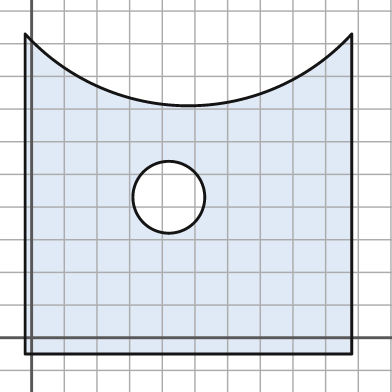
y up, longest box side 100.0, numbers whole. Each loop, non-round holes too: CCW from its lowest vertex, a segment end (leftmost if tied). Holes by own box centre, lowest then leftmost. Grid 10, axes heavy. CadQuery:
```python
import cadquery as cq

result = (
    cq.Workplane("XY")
    .moveTo(-2.0, -5.0)
    .lineTo(98.0, -5.0)
    .lineTo(98.0, 93.0)
    .threePointArc((48.0, 71.0), (-2.0, 93.0))
    .close()
    .moveTo(42.0, 43.0)
    .circle(11.0)
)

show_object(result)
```